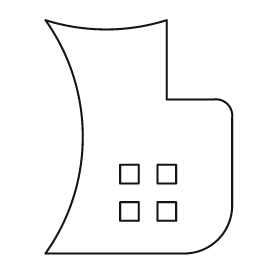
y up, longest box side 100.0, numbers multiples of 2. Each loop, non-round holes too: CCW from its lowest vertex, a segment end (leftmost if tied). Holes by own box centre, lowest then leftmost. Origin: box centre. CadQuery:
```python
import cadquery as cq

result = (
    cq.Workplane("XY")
    .moveTo(-40.0, -50.0)
    .lineTo(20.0, -50.0)
    .threePointArc((34.0, -44.0), (40.0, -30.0))
    .lineTo(40.0, 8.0)
    .threePointArc((38.0, 14.0), (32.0, 16.0))
    .lineTo(12.0, 16.0)
    .lineTo(12.0, 50.0)
    .threePointArc((-14.0, 46.0), (-40.0, 50.0))
    .threePointArc((-24.0, 0.0), (-40.0, -50.0))
    .close()
    .moveTo(-8.0, -36.0)
    .lineTo(0.0, -36.0)
    .lineTo(0.0, -28.0)
    .lineTo(-8.0, -28.0)
    .close()
    .moveTo(8.0, -36.0)
    .lineTo(16.0, -36.0)
    .lineTo(16.0, -28.0)
    .lineTo(8.0, -28.0)
    .close()
    .moveTo(-8.0, -20.0)
    .lineTo(0.0, -20.0)
    .lineTo(0.0, -12.0)
    .lineTo(-8.0, -12.0)
    .close()
    .moveTo(8.0, -20.0)
    .lineTo(16.0, -20.0)
    .lineTo(16.0, -12.0)
    .lineTo(8.0, -12.0)
    .close()
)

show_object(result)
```